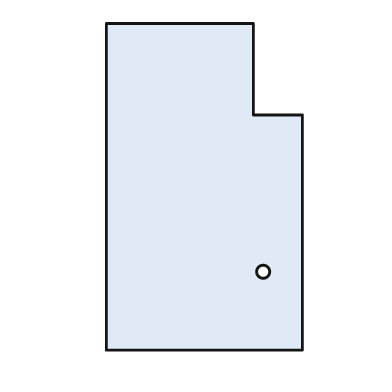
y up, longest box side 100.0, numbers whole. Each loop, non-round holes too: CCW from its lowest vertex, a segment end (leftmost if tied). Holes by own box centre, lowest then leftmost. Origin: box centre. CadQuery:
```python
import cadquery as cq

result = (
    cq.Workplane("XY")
    .moveTo(-30.0, -50.0)
    .lineTo(30.0, -50.0)
    .lineTo(30.0, 22.0)
    .lineTo(15.0, 22.0)
    .lineTo(15.0, 50.0)
    .lineTo(-30.0, 50.0)
    .close()
    .moveTo(18.0, -26.0)
    .circle(2.0)
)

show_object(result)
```